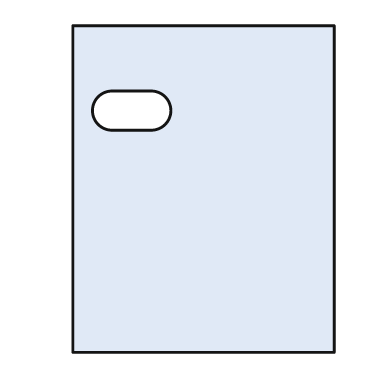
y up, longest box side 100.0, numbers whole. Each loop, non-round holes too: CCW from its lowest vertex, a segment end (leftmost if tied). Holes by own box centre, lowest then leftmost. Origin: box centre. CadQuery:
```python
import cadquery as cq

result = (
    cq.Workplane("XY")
    .moveTo(-40.0, -50.0)
    .lineTo(40.0, -50.0)
    .lineTo(40.0, 50.0)
    .lineTo(-40.0, 50.0)
    .close()
    .moveTo(-28.0, 18.0)
    .lineTo(-16.0, 18.0)
    .threePointArc((-10.0, 24.0), (-16.0, 30.0))
    .lineTo(-28.0, 30.0)
    .threePointArc((-34.0, 24.0), (-28.0, 18.0))
    .close()
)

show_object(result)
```